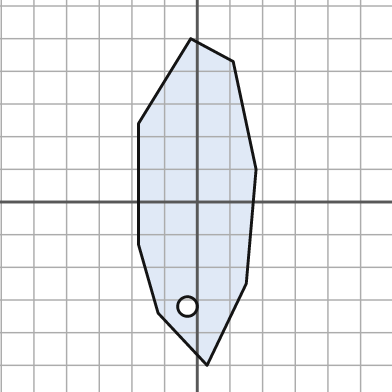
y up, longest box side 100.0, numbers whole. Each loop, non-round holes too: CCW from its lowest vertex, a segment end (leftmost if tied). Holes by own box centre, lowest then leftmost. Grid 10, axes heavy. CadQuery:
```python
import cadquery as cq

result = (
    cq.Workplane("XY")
    .moveTo(3.0, -50.0)
    .lineTo(15.0, -25.0)
    .lineTo(18.0, 10.0)
    .lineTo(11.0, 43.0)
    .lineTo(-2.0, 50.0)
    .lineTo(-18.0, 24.0)
    .lineTo(-18.0, -13.0)
    .lineTo(-12.0, -34.0)
    .close()
    .moveTo(-3.0, -32.0)
    .circle(3.0)
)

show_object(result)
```